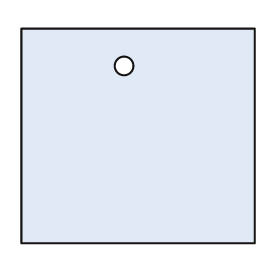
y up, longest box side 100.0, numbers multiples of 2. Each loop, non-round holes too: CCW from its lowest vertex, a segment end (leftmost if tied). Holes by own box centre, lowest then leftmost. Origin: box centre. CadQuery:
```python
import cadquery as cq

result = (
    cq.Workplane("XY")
    .moveTo(-50.0, -46.0)
    .lineTo(50.0, -46.0)
    .lineTo(50.0, 46.0)
    .lineTo(-50.0, 46.0)
    .close()
    .moveTo(-6.0, 30.0)
    .circle(4.0)
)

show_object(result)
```